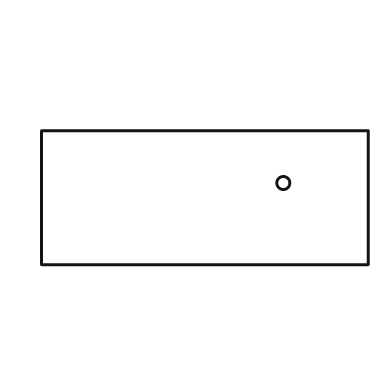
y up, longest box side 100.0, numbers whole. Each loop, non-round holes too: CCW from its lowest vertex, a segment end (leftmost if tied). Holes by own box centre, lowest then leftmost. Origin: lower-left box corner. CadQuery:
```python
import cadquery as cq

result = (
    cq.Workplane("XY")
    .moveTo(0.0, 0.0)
    .lineTo(100.0, 0.0)
    .lineTo(100.0, 41.0)
    .lineTo(0.0, 41.0)
    .close()
    .moveTo(74.0, 25.0)
    .circle(2.0)
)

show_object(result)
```